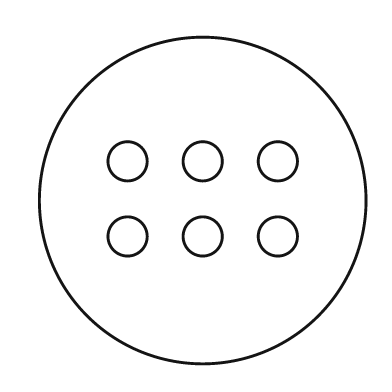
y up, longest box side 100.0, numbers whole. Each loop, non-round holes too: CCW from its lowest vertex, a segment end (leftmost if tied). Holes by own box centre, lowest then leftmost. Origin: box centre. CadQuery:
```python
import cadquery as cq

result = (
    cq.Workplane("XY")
    .moveTo(0.0, 0.0)
    .circle(50.0)
    .moveTo(-23.0, -11.0)
    .circle(6.0)
    .moveTo(0.0, -11.0)
    .circle(6.0)
    .moveTo(23.0, -11.0)
    .circle(6.0)
    .moveTo(-23.0, 12.0)
    .circle(6.0)
    .moveTo(0.0, 12.0)
    .circle(6.0)
    .moveTo(23.0, 12.0)
    .circle(6.0)
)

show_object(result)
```